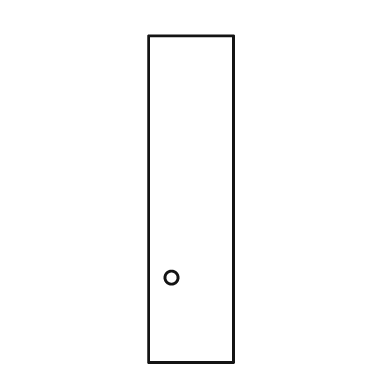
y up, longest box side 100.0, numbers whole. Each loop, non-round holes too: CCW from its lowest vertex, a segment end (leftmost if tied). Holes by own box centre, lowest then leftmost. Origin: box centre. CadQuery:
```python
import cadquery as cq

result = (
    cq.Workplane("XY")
    .moveTo(-13.0, -50.0)
    .lineTo(13.0, -50.0)
    .lineTo(13.0, 50.0)
    .lineTo(-13.0, 50.0)
    .close()
    .moveTo(-6.0, -24.0)
    .circle(2.0)
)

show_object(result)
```